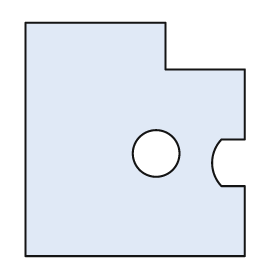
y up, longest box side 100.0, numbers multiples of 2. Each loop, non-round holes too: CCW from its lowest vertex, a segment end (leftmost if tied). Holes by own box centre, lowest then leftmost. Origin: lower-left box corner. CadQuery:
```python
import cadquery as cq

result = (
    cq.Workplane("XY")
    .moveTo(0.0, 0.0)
    .lineTo(94.0, 0.0)
    .lineTo(94.0, 30.0)
    .lineTo(84.0, 30.0)
    .threePointArc((80.0, 40.0), (84.0, 50.0))
    .lineTo(94.0, 50.0)
    .lineTo(94.0, 80.0)
    .lineTo(60.0, 80.0)
    .lineTo(60.0, 100.0)
    .lineTo(0.0, 100.0)
    .close()
    .moveTo(56.0, 44.0)
    .circle(10.0)
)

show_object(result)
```